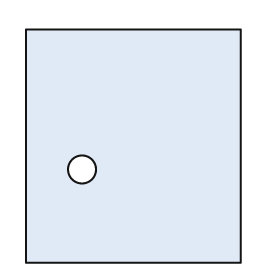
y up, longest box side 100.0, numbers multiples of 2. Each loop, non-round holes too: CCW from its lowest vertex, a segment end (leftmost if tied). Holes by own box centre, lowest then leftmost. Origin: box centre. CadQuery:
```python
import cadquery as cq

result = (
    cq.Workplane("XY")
    .moveTo(-46.0, -50.0)
    .lineTo(46.0, -50.0)
    .lineTo(46.0, 50.0)
    .lineTo(-46.0, 50.0)
    .close()
    .moveTo(-22.0, -10.0)
    .circle(6.0)
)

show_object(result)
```